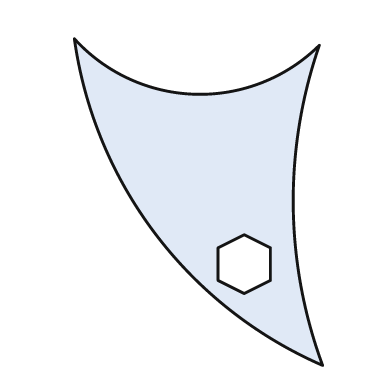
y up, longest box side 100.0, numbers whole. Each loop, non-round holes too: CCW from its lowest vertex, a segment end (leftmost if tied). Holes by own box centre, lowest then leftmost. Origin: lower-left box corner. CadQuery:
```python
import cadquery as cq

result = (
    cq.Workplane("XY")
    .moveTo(76.0, 0.0)
    .threePointArc((67.0, 49.0), (75.0, 98.0))
    .threePointArc((37.0, 83.0), (0.0, 100.0))
    .threePointArc((25.0, 40.0), (76.0, 0.0))
    .close()
    .moveTo(52.0, 22.0)
    .lineTo(60.0, 26.0)
    .lineTo(60.0, 36.0)
    .lineTo(52.0, 40.0)
    .lineTo(44.0, 36.0)
    .lineTo(44.0, 26.0)
    .close()
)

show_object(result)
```